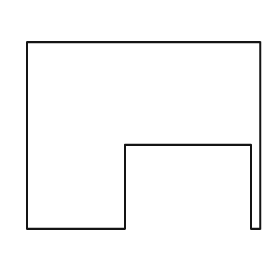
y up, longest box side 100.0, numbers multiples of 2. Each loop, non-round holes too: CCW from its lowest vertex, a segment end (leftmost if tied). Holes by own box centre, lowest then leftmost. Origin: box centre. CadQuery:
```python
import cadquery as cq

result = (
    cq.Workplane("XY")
    .moveTo(-50.0, -40.0)
    .lineTo(-8.0, -40.0)
    .lineTo(-8.0, -4.0)
    .lineTo(46.0, -4.0)
    .lineTo(46.0, -40.0)
    .lineTo(50.0, -40.0)
    .lineTo(50.0, 40.0)
    .lineTo(-50.0, 40.0)
    .close()
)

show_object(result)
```